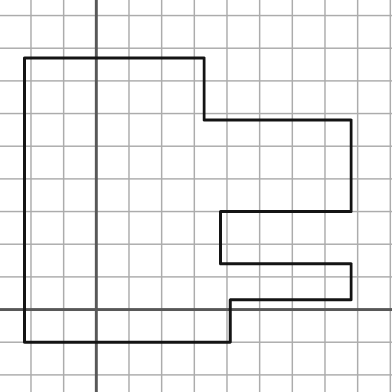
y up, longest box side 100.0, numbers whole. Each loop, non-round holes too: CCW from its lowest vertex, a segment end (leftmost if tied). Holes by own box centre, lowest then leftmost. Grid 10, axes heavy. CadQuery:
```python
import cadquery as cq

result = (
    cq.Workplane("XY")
    .moveTo(-22.0, -10.0)
    .lineTo(41.0, -10.0)
    .lineTo(41.0, 3.0)
    .lineTo(78.0, 3.0)
    .lineTo(78.0, 14.0)
    .lineTo(38.0, 14.0)
    .lineTo(38.0, 30.0)
    .lineTo(78.0, 30.0)
    .lineTo(78.0, 58.0)
    .lineTo(33.0, 58.0)
    .lineTo(33.0, 77.0)
    .lineTo(-22.0, 77.0)
    .close()
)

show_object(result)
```